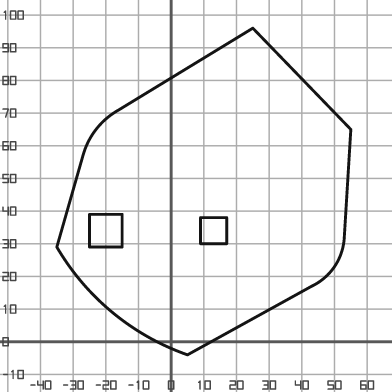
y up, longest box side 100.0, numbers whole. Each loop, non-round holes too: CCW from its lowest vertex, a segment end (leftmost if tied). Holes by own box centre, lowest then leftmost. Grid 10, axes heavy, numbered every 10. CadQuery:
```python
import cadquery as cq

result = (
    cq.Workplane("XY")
    .moveTo(5.0, -4.0)
    .lineTo(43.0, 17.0)
    .threePointArc((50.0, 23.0), (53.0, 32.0))
    .lineTo(55.0, 65.0)
    .lineTo(25.0, 96.0)
    .lineTo(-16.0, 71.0)
    .threePointArc((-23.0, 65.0), (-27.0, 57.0))
    .lineTo(-35.0, 29.0)
    .threePointArc((-18.0, 9.0), (5.0, -4.0))
    .close()
    .moveTo(-25.0, 29.0)
    .lineTo(-15.0, 29.0)
    .lineTo(-15.0, 39.0)
    .lineTo(-25.0, 39.0)
    .close()
    .moveTo(9.0, 30.0)
    .lineTo(17.0, 30.0)
    .lineTo(17.0, 38.0)
    .lineTo(9.0, 38.0)
    .close()
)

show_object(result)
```